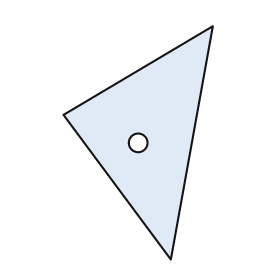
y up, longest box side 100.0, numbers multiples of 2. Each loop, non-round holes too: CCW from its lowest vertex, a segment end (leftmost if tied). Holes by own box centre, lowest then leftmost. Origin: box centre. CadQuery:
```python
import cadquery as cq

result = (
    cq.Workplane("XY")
    .moveTo(14.0, -50.0)
    .lineTo(32.0, 50.0)
    .lineTo(-32.0, 12.0)
    .close()
    .moveTo(0.0, 0.0)
    .circle(4.0)
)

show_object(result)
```